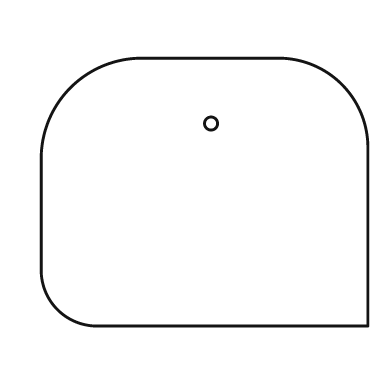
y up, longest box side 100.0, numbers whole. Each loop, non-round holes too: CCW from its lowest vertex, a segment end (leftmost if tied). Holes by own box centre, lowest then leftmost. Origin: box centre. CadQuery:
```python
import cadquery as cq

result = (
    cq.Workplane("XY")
    .moveTo(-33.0, -41.0)
    .lineTo(50.0, -41.0)
    .lineTo(50.0, 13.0)
    .threePointArc((42.0, 33.0), (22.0, 41.0))
    .lineTo(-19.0, 41.0)
    .threePointArc((-41.0, 32.0), (-50.0, 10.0))
    .lineTo(-50.0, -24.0)
    .threePointArc((-45.0, -36.0), (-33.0, -41.0))
    .close()
    .moveTo(2.0, 21.0)
    .circle(2.0)
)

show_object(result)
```